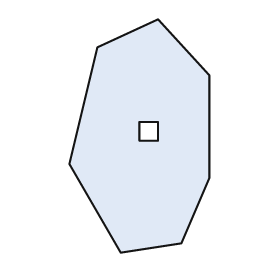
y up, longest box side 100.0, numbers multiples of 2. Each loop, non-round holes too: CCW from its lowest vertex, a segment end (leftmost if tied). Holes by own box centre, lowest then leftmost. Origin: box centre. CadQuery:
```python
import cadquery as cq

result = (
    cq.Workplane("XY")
    .moveTo(-8.0, -50.0)
    .lineTo(18.0, -46.0)
    .lineTo(30.0, -18.0)
    .lineTo(30.0, 26.0)
    .lineTo(8.0, 50.0)
    .lineTo(-18.0, 38.0)
    .lineTo(-30.0, -12.0)
    .close()
    .moveTo(0.0, -2.0)
    .lineTo(8.0, -2.0)
    .lineTo(8.0, 6.0)
    .lineTo(0.0, 6.0)
    .close()
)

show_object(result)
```